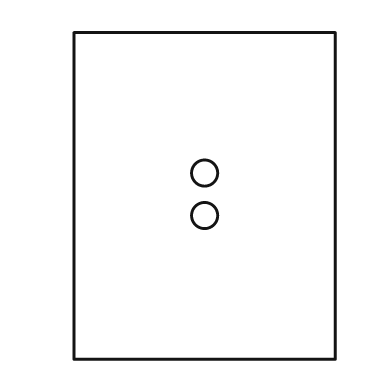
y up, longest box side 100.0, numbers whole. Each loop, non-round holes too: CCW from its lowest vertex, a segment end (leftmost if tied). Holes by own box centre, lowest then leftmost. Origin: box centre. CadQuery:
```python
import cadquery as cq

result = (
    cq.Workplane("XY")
    .moveTo(-40.0, -50.0)
    .lineTo(40.0, -50.0)
    .lineTo(40.0, 50.0)
    .lineTo(-40.0, 50.0)
    .close()
    .moveTo(0.0, -6.0)
    .circle(4.0)
    .moveTo(0.0, 7.0)
    .circle(4.0)
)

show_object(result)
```